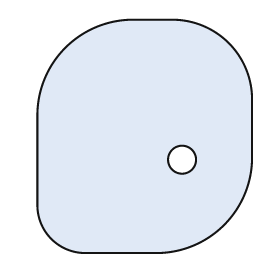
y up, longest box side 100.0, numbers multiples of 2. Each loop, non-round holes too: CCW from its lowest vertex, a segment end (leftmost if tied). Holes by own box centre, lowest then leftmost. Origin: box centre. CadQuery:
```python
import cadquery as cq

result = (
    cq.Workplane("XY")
    .moveTo(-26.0, -50.0)
    .lineTo(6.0, -50.0)
    .threePointArc((34.0, -38.0), (46.0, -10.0))
    .lineTo(46.0, 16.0)
    .threePointArc((36.0, 40.0), (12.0, 50.0))
    .lineTo(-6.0, 50.0)
    .threePointArc((-34.0, 38.0), (-46.0, 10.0))
    .lineTo(-46.0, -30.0)
    .threePointArc((-40.0, -44.0), (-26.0, -50.0))
    .close()
    .moveTo(16.0, -10.0)
    .circle(6.0)
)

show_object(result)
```